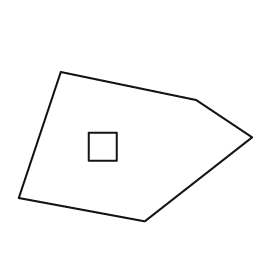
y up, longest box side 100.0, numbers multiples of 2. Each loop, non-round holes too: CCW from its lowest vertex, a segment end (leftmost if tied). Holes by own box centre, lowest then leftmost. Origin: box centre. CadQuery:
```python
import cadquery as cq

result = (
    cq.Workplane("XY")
    .moveTo(4.0, -32.0)
    .lineTo(50.0, 4.0)
    .lineTo(26.0, 20.0)
    .lineTo(-32.0, 32.0)
    .lineTo(-50.0, -22.0)
    .close()
    .moveTo(-20.0, -6.0)
    .lineTo(-8.0, -6.0)
    .lineTo(-8.0, 6.0)
    .lineTo(-20.0, 6.0)
    .close()
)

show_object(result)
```